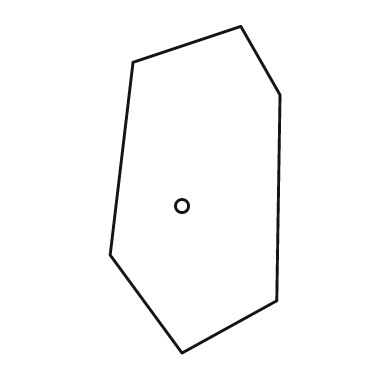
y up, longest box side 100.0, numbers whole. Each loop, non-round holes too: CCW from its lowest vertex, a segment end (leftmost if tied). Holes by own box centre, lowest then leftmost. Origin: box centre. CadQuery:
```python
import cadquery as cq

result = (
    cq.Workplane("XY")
    .moveTo(-4.0, -50.0)
    .lineTo(25.0, -34.0)
    .lineTo(26.0, 29.0)
    .lineTo(14.0, 50.0)
    .lineTo(-19.0, 39.0)
    .lineTo(-26.0, -20.0)
    .close()
    .moveTo(-4.0, -5.0)
    .circle(2.0)
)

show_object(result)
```